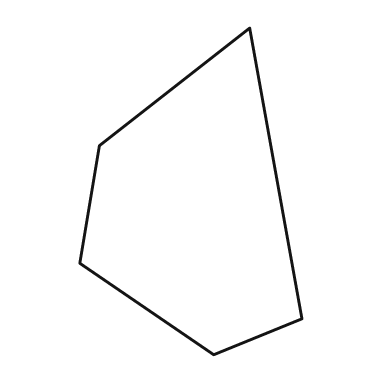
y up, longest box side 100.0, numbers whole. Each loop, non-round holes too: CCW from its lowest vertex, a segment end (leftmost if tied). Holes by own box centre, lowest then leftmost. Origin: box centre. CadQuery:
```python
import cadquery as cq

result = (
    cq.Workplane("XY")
    .moveTo(7.0, -50.0)
    .lineTo(34.0, -39.0)
    .lineTo(18.0, 50.0)
    .lineTo(-28.0, 14.0)
    .lineTo(-34.0, -22.0)
    .close()
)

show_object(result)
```